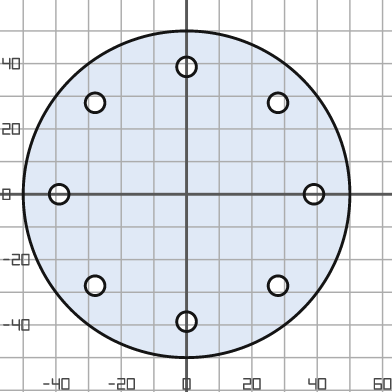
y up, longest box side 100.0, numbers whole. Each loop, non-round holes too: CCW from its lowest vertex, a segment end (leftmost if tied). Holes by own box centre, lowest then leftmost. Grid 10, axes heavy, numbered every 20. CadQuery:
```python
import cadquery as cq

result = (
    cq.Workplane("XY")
    .moveTo(0.0, 0.0)
    .circle(50.0)
    .moveTo(0.0, -39.0)
    .circle(3.0)
    .moveTo(-28.0, -28.0)
    .circle(3.0)
    .moveTo(28.0, -28.0)
    .circle(3.0)
    .moveTo(-39.0, 0.0)
    .circle(3.0)
    .moveTo(39.0, 0.0)
    .circle(3.0)
    .moveTo(-28.0, 28.0)
    .circle(3.0)
    .moveTo(28.0, 28.0)
    .circle(3.0)
    .moveTo(0.0, 39.0)
    .circle(3.0)
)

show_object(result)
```